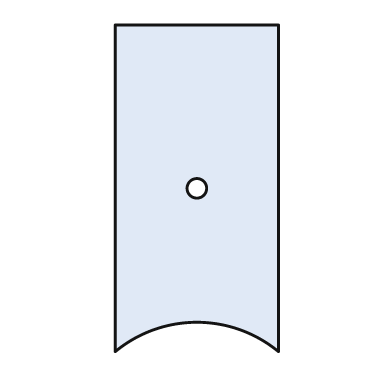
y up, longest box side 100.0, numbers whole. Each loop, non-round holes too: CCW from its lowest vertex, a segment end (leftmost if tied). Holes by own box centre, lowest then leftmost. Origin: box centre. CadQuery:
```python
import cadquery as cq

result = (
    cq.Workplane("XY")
    .moveTo(-25.0, -50.0)
    .threePointArc((0.0, -41.0), (25.0, -50.0))
    .lineTo(25.0, 50.0)
    .lineTo(-25.0, 50.0)
    .close()
    .moveTo(0.0, 0.0)
    .circle(3.0)
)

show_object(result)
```